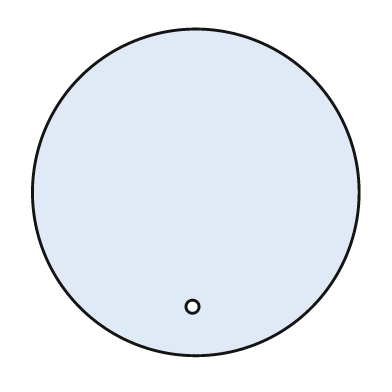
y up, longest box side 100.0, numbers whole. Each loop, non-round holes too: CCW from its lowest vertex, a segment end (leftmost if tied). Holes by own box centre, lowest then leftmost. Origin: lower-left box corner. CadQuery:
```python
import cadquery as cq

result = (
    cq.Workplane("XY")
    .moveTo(50.0, 50.0)
    .circle(50.0)
    .moveTo(49.0, 15.0)
    .circle(2.0)
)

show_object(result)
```